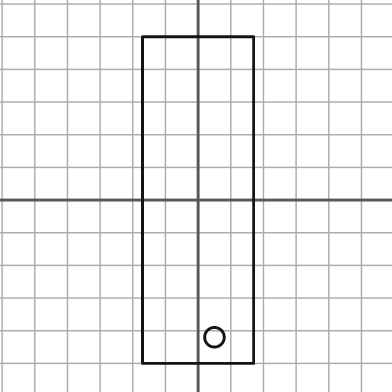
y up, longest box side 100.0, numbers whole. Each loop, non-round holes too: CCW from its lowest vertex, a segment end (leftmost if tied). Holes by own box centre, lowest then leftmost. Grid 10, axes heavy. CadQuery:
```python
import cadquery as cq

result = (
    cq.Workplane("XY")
    .moveTo(-17.0, -50.0)
    .lineTo(17.0, -50.0)
    .lineTo(17.0, 50.0)
    .lineTo(-17.0, 50.0)
    .close()
    .moveTo(5.0, -42.0)
    .circle(3.0)
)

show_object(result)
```